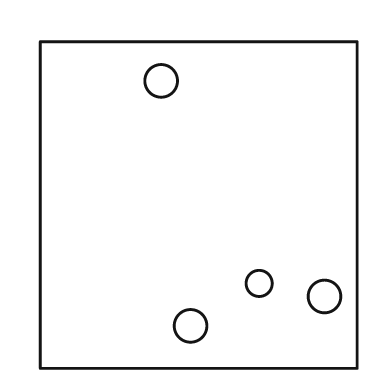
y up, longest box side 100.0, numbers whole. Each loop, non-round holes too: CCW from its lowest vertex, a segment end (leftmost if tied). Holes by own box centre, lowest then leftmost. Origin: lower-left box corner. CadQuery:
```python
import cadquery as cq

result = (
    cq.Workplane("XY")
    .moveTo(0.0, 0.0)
    .lineTo(97.0, 0.0)
    .lineTo(97.0, 100.0)
    .lineTo(0.0, 100.0)
    .close()
    .moveTo(46.0, 13.0)
    .circle(5.0)
    .moveTo(87.0, 22.0)
    .circle(5.0)
    .moveTo(67.0, 26.0)
    .circle(4.0)
    .moveTo(37.0, 88.0)
    .circle(5.0)
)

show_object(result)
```